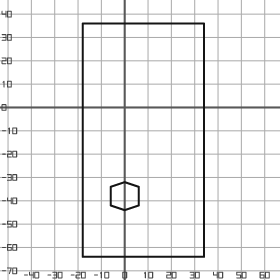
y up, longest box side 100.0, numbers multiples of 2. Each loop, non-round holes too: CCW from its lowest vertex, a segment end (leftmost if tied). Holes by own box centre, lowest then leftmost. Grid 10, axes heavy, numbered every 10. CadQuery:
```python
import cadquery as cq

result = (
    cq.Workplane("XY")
    .moveTo(-18.0, -64.0)
    .lineTo(34.0, -64.0)
    .lineTo(34.0, 36.0)
    .lineTo(-18.0, 36.0)
    .close()
    .moveTo(0.0, -44.0)
    .lineTo(6.0, -42.0)
    .lineTo(6.0, -34.0)
    .lineTo(0.0, -32.0)
    .lineTo(-6.0, -34.0)
    .lineTo(-6.0, -42.0)
    .close()
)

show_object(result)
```